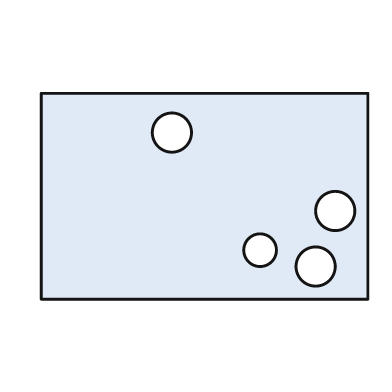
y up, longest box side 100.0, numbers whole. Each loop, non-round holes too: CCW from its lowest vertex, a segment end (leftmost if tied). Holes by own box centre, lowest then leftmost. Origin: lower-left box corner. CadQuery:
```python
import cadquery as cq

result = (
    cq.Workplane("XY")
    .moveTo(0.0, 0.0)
    .lineTo(100.0, 0.0)
    .lineTo(100.0, 63.0)
    .lineTo(0.0, 63.0)
    .close()
    .moveTo(84.0, 10.0)
    .circle(6.0)
    .moveTo(67.0, 15.0)
    .circle(5.0)
    .moveTo(90.0, 27.0)
    .circle(6.0)
    .moveTo(40.0, 51.0)
    .circle(6.0)
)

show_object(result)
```